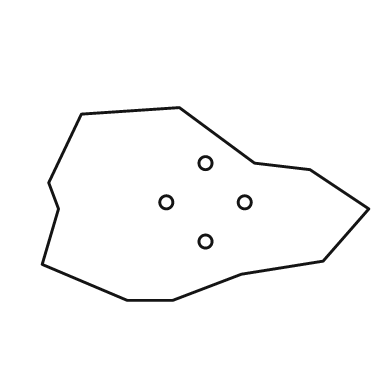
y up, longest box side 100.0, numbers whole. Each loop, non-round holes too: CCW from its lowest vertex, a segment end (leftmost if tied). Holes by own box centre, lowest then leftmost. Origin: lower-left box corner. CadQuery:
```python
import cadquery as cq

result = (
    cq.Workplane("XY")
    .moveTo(26.0, 0.0)
    .lineTo(40.0, 0.0)
    .lineTo(61.0, 8.0)
    .lineTo(86.0, 12.0)
    .lineTo(100.0, 28.0)
    .lineTo(82.0, 40.0)
    .lineTo(65.0, 42.0)
    .lineTo(42.0, 59.0)
    .lineTo(12.0, 57.0)
    .lineTo(2.0, 36.0)
    .lineTo(5.0, 28.0)
    .lineTo(0.0, 11.0)
    .close()
    .moveTo(50.0, 18.0)
    .circle(2.0)
    .moveTo(38.0, 30.0)
    .circle(2.0)
    .moveTo(62.0, 30.0)
    .circle(2.0)
    .moveTo(50.0, 42.0)
    .circle(2.0)
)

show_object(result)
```